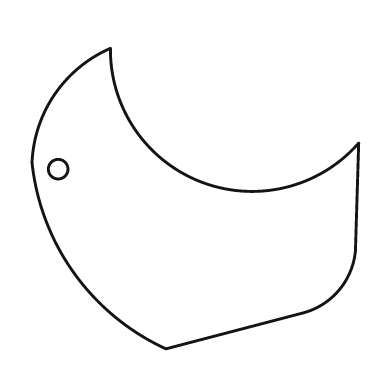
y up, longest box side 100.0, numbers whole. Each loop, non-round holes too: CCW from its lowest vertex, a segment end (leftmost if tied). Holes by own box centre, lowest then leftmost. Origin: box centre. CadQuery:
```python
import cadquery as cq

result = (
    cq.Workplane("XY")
    .moveTo(-9.0, -46.0)
    .lineTo(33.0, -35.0)
    .threePointArc((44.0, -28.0), (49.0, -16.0))
    .lineTo(50.0, 17.0)
    .threePointArc((2.0, 5.0), (-26.0, 46.0))
    .threePointArc((-43.0, 32.0), (-50.0, 11.0))
    .threePointArc((-37.0, -23.0), (-9.0, -46.0))
    .close()
    .moveTo(-42.0, 9.0)
    .circle(3.0)
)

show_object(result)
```